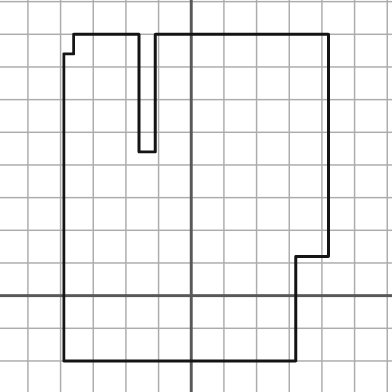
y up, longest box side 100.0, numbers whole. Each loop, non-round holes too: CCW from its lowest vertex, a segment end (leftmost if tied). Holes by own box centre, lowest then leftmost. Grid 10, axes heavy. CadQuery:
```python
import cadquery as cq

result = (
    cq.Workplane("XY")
    .moveTo(-39.0, -20.0)
    .lineTo(32.0, -20.0)
    .lineTo(32.0, 12.0)
    .lineTo(42.0, 12.0)
    .lineTo(42.0, 80.0)
    .lineTo(-11.0, 80.0)
    .lineTo(-11.0, 44.0)
    .lineTo(-16.0, 44.0)
    .lineTo(-16.0, 80.0)
    .lineTo(-36.0, 80.0)
    .lineTo(-36.0, 74.0)
    .lineTo(-39.0, 74.0)
    .close()
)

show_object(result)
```